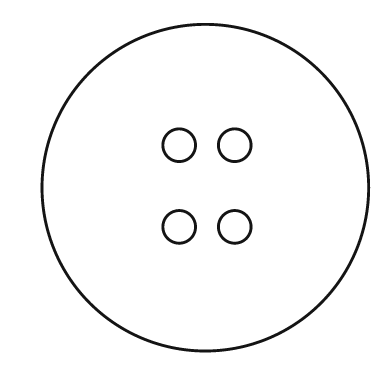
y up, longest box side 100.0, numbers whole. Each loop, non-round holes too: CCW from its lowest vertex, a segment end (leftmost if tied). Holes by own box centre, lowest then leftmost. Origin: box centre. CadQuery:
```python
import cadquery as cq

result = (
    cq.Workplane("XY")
    .moveTo(0.0, 0.0)
    .circle(50.0)
    .moveTo(-8.0, -12.0)
    .circle(5.0)
    .moveTo(9.0, -12.0)
    .circle(5.0)
    .moveTo(-8.0, 13.0)
    .circle(5.0)
    .moveTo(9.0, 13.0)
    .circle(5.0)
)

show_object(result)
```